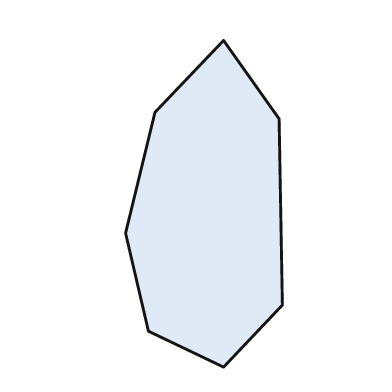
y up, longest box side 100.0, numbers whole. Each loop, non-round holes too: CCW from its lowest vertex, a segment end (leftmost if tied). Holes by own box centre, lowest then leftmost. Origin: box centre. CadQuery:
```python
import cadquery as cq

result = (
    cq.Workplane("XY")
    .moveTo(6.0, -50.0)
    .lineTo(24.0, -31.0)
    .lineTo(23.0, 26.0)
    .lineTo(6.0, 50.0)
    .lineTo(-15.0, 28.0)
    .lineTo(-24.0, -9.0)
    .lineTo(-17.0, -39.0)
    .close()
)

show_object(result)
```